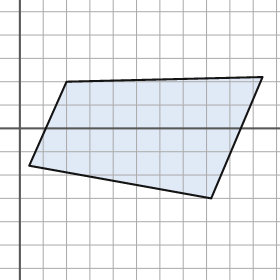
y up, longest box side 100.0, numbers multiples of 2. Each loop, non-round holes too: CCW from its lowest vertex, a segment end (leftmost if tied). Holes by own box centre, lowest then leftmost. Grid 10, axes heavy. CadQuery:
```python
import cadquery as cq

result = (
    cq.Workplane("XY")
    .moveTo(82.0, -30.0)
    .lineTo(104.0, 22.0)
    .lineTo(20.0, 20.0)
    .lineTo(4.0, -16.0)
    .close()
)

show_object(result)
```